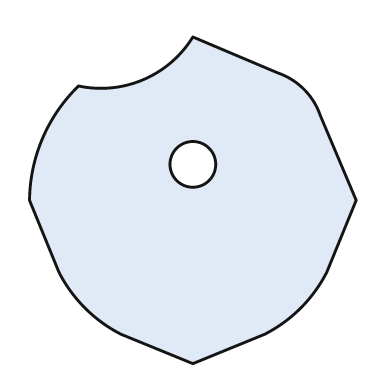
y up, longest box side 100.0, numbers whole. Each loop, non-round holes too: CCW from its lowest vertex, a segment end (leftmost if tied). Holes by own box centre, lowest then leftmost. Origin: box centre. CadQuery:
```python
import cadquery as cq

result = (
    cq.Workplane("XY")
    .moveTo(0.0, -50.0)
    .lineTo(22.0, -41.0)
    .threePointArc((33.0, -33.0), (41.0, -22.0))
    .lineTo(50.0, 0.0)
    .lineTo(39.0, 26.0)
    .threePointArc((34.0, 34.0), (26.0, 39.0))
    .lineTo(0.0, 50.0)
    .threePointArc((-15.0, 37.0), (-35.0, 35.0))
    .threePointArc((-46.0, 19.0), (-50.0, 0.0))
    .lineTo(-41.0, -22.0)
    .threePointArc((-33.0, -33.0), (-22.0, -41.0))
    .close()
    .moveTo(0.0, 11.0)
    .circle(7.0)
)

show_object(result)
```